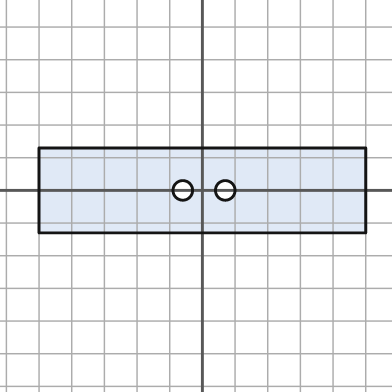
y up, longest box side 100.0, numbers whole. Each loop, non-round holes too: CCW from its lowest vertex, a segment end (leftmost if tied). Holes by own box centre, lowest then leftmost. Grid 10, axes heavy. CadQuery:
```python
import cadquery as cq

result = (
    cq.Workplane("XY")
    .moveTo(-50.0, -13.0)
    .lineTo(50.0, -13.0)
    .lineTo(50.0, 13.0)
    .lineTo(-50.0, 13.0)
    .close()
    .moveTo(-6.0, 0.0)
    .circle(3.0)
    .moveTo(7.0, 0.0)
    .circle(3.0)
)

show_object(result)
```